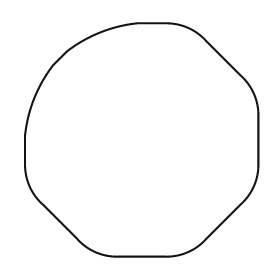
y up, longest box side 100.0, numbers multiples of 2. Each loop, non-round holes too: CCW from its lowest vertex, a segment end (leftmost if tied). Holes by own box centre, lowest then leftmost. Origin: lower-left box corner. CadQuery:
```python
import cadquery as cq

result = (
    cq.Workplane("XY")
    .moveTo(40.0, 0.0)
    .lineTo(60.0, 0.0)
    .threePointArc((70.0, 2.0), (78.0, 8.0))
    .lineTo(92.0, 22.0)
    .threePointArc((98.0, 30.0), (100.0, 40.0))
    .lineTo(100.0, 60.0)
    .threePointArc((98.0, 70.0), (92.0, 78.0))
    .lineTo(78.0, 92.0)
    .threePointArc((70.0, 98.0), (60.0, 100.0))
    .lineTo(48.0, 100.0)
    .threePointArc((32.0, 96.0), (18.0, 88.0))
    .lineTo(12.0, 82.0)
    .threePointArc((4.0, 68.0), (0.0, 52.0))
    .lineTo(0.0, 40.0)
    .threePointArc((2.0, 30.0), (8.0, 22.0))
    .lineTo(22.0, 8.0)
    .threePointArc((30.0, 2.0), (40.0, 0.0))
    .close()
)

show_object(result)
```